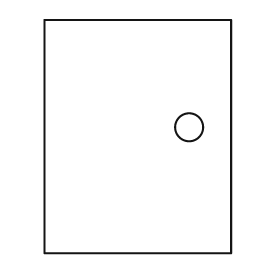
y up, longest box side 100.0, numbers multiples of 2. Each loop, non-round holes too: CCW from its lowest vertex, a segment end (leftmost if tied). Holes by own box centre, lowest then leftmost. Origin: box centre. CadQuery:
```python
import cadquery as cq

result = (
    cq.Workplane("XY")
    .moveTo(-40.0, -50.0)
    .lineTo(40.0, -50.0)
    .lineTo(40.0, 50.0)
    .lineTo(-40.0, 50.0)
    .close()
    .moveTo(22.0, 4.0)
    .circle(6.0)
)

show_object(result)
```